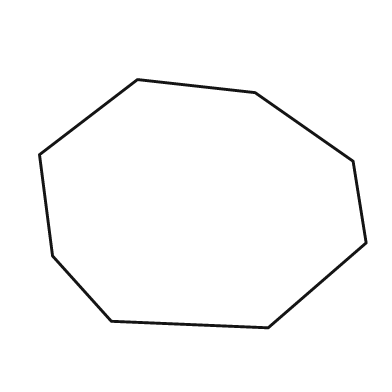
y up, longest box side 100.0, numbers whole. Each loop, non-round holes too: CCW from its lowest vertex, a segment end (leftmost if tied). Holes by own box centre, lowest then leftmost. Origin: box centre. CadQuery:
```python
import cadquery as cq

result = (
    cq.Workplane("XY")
    .moveTo(20.0, -38.0)
    .lineTo(50.0, -12.0)
    .lineTo(46.0, 13.0)
    .lineTo(16.0, 34.0)
    .lineTo(-20.0, 38.0)
    .lineTo(-50.0, 15.0)
    .lineTo(-46.0, -16.0)
    .lineTo(-28.0, -36.0)
    .close()
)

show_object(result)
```